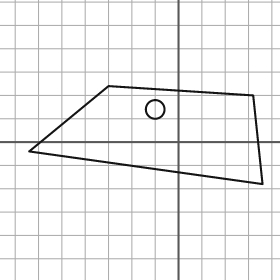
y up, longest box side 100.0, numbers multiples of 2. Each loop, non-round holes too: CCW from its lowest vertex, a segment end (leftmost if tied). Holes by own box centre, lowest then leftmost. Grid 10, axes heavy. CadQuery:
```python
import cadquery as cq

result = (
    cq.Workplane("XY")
    .moveTo(36.0, -18.0)
    .lineTo(32.0, 20.0)
    .lineTo(-30.0, 24.0)
    .lineTo(-64.0, -4.0)
    .close()
    .moveTo(-10.0, 14.0)
    .circle(4.0)
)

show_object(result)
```